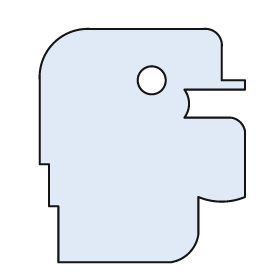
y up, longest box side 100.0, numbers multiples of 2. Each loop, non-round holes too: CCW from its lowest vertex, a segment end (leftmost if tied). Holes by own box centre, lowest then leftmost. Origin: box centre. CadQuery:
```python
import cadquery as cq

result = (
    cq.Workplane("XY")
    .moveTo(-36.0, -50.0)
    .lineTo(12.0, -50.0)
    .threePointArc((20.0, -46.0), (24.0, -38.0))
    .lineTo(24.0, -22.0)
    .threePointArc((34.0, -24.0), (44.0, -22.0))
    .lineTo(44.0, 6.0)
    .threePointArc((42.0, 10.0), (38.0, 12.0))
    .lineTo(18.0, 12.0)
    .threePointArc((20.0, 18.0), (18.0, 24.0))
    .lineTo(44.0, 24.0)
    .lineTo(44.0, 28.0)
    .lineTo(34.0, 28.0)
    .lineTo(34.0, 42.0)
    .threePointArc((32.0, 48.0), (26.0, 50.0))
    .lineTo(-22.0, 50.0)
    .threePointArc((-38.0, 44.0), (-44.0, 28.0))
    .lineTo(-44.0, -8.0)
    .lineTo(-40.0, -8.0)
    .lineTo(-40.0, -26.0)
    .lineTo(-36.0, -26.0)
    .close()
    .moveTo(4.0, 28.0)
    .circle(6.0)
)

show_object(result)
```